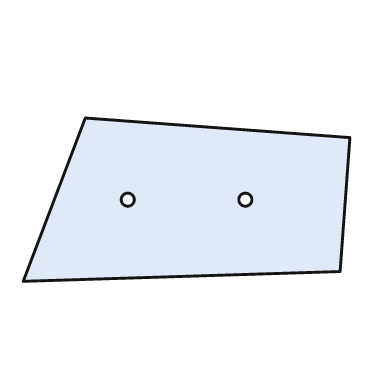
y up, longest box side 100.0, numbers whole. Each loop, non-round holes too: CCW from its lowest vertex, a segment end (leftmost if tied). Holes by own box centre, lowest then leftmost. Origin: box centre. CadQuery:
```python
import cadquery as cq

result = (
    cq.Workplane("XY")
    .moveTo(-50.0, -25.0)
    .lineTo(47.0, -22.0)
    .lineTo(50.0, 19.0)
    .lineTo(-31.0, 25.0)
    .close()
    .moveTo(-18.0, 0.0)
    .circle(2.0)
    .moveTo(18.0, 0.0)
    .circle(2.0)
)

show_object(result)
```